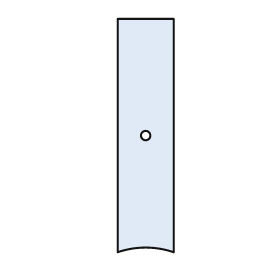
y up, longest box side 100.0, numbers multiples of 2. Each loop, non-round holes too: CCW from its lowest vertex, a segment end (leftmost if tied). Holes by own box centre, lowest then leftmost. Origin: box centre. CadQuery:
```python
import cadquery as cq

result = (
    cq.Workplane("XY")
    .moveTo(-12.0, -50.0)
    .threePointArc((0.0, -48.0), (12.0, -50.0))
    .lineTo(12.0, 50.0)
    .lineTo(-12.0, 50.0)
    .close()
    .moveTo(0.0, 0.0)
    .circle(2.0)
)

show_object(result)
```